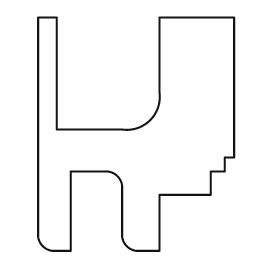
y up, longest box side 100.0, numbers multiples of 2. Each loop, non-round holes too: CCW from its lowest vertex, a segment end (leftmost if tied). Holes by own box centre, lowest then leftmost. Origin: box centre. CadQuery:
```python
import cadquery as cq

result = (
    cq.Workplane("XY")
    .moveTo(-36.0, -50.0)
    .lineTo(-28.0, -50.0)
    .lineTo(-28.0, -16.0)
    .lineTo(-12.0, -16.0)
    .threePointArc((-8.0, -18.0), (-6.0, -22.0))
    .lineTo(-6.0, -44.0)
    .threePointArc((-4.0, -48.0), (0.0, -50.0))
    .lineTo(10.0, -50.0)
    .lineTo(10.0, -26.0)
    .lineTo(32.0, -26.0)
    .lineTo(32.0, -16.0)
    .lineTo(38.0, -16.0)
    .lineTo(38.0, -10.0)
    .lineTo(42.0, -10.0)
    .lineTo(42.0, 50.0)
    .lineTo(10.0, 50.0)
    .lineTo(10.0, 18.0)
    .threePointArc((6.0, 6.0), (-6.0, 2.0))
    .lineTo(-34.0, 2.0)
    .lineTo(-34.0, 50.0)
    .lineTo(-42.0, 50.0)
    .lineTo(-42.0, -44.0)
    .threePointArc((-40.0, -48.0), (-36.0, -50.0))
    .close()
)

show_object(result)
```